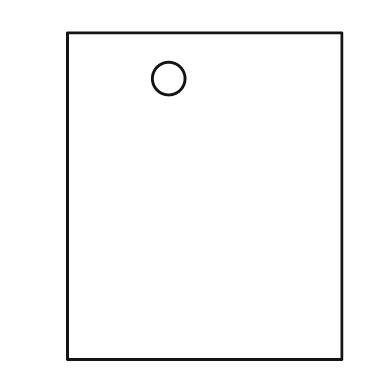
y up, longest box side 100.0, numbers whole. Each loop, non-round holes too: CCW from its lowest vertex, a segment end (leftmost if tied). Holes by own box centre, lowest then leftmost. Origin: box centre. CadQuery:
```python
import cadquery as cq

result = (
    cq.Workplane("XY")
    .moveTo(-42.0, -50.0)
    .lineTo(42.0, -50.0)
    .lineTo(42.0, 50.0)
    .lineTo(-42.0, 50.0)
    .close()
    .moveTo(-11.0, 36.0)
    .circle(5.0)
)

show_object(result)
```